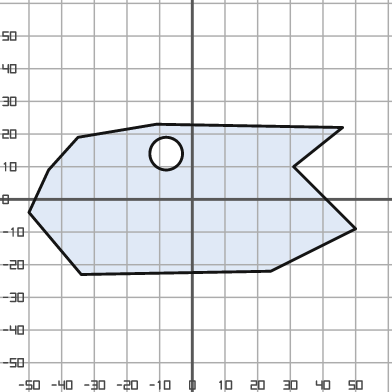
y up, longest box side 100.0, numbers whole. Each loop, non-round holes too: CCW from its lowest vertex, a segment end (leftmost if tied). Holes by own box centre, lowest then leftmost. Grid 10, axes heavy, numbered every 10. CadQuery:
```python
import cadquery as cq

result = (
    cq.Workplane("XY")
    .moveTo(-34.0, -23.0)
    .lineTo(24.0, -22.0)
    .lineTo(50.0, -9.0)
    .lineTo(31.0, 10.0)
    .lineTo(46.0, 22.0)
    .lineTo(-11.0, 23.0)
    .lineTo(-35.0, 19.0)
    .lineTo(-44.0, 9.0)
    .lineTo(-50.0, -4.0)
    .close()
    .moveTo(-8.0, 14.0)
    .circle(5.0)
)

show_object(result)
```